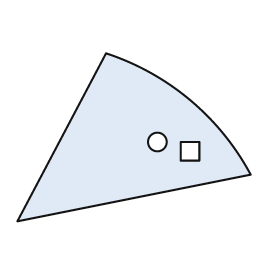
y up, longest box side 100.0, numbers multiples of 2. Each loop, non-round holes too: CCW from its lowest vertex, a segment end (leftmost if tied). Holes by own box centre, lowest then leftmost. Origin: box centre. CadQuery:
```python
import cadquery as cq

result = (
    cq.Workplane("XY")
    .moveTo(-50.0, -36.0)
    .lineTo(50.0, -16.0)
    .threePointArc((24.0, 16.0), (-12.0, 36.0))
    .close()
    .moveTo(20.0, -10.0)
    .lineTo(28.0, -10.0)
    .lineTo(28.0, -2.0)
    .lineTo(20.0, -2.0)
    .close()
    .moveTo(10.0, -2.0)
    .circle(4.0)
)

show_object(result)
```